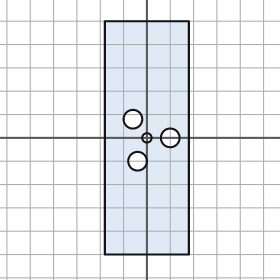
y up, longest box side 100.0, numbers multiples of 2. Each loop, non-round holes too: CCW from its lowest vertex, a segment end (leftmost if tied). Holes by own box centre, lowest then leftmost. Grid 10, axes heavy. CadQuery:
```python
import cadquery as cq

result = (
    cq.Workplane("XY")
    .moveTo(-18.0, -50.0)
    .lineTo(18.0, -50.0)
    .lineTo(18.0, 50.0)
    .lineTo(-18.0, 50.0)
    .close()
    .moveTo(-4.0, -10.0)
    .circle(4.0)
    .moveTo(0.0, 0.0)
    .circle(2.0)
    .moveTo(10.0, 0.0)
    .circle(4.0)
    .moveTo(-6.0, 8.0)
    .circle(4.0)
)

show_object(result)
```